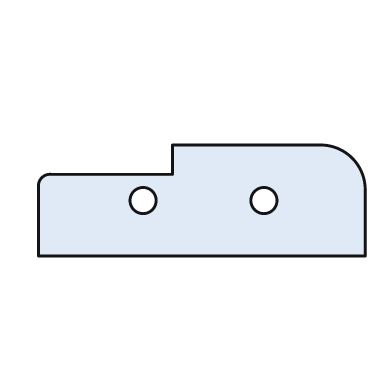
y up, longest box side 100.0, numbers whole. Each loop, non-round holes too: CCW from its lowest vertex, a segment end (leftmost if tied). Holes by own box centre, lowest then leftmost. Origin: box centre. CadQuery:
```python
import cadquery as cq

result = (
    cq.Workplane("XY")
    .moveTo(-50.0, -17.0)
    .lineTo(50.0, -17.0)
    .lineTo(50.0, 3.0)
    .threePointArc((46.0, 13.0), (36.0, 17.0))
    .lineTo(-9.0, 17.0)
    .lineTo(-9.0, 8.0)
    .lineTo(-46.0, 8.0)
    .threePointArc((-49.0, 7.0), (-50.0, 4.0))
    .close()
    .moveTo(-18.0, 0.0)
    .circle(4.0)
    .moveTo(19.0, 0.0)
    .circle(4.0)
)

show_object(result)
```